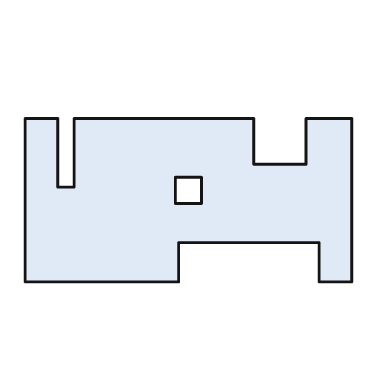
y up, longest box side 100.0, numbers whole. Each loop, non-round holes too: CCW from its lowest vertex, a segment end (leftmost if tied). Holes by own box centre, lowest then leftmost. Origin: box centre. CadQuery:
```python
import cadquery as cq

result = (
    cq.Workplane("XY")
    .moveTo(-50.0, -25.0)
    .lineTo(-3.0, -25.0)
    .lineTo(-3.0, -13.0)
    .lineTo(40.0, -13.0)
    .lineTo(40.0, -25.0)
    .lineTo(50.0, -25.0)
    .lineTo(50.0, 25.0)
    .lineTo(36.0, 25.0)
    .lineTo(36.0, 11.0)
    .lineTo(20.0, 11.0)
    .lineTo(20.0, 25.0)
    .lineTo(-35.0, 25.0)
    .lineTo(-35.0, 4.0)
    .lineTo(-40.0, 4.0)
    .lineTo(-40.0, 25.0)
    .lineTo(-50.0, 25.0)
    .close()
    .moveTo(-4.0, -1.0)
    .lineTo(4.0, -1.0)
    .lineTo(4.0, 7.0)
    .lineTo(-4.0, 7.0)
    .close()
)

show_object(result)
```